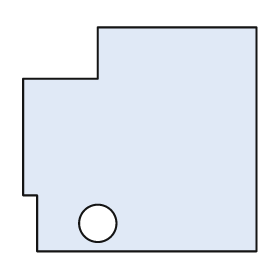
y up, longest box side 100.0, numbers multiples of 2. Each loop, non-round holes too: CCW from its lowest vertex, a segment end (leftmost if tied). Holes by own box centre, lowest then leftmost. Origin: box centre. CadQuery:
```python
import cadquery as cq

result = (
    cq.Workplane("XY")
    .moveTo(-44.0, -48.0)
    .lineTo(50.0, -48.0)
    .lineTo(50.0, 48.0)
    .lineTo(-18.0, 48.0)
    .lineTo(-18.0, 26.0)
    .lineTo(-50.0, 26.0)
    .lineTo(-50.0, -24.0)
    .lineTo(-44.0, -24.0)
    .close()
    .moveTo(-18.0, -36.0)
    .circle(8.0)
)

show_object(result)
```